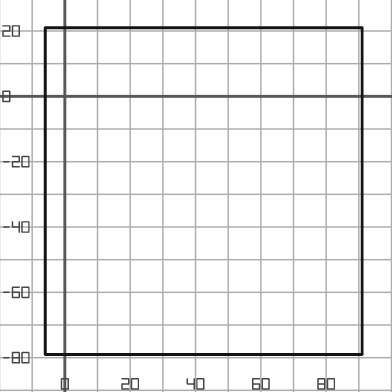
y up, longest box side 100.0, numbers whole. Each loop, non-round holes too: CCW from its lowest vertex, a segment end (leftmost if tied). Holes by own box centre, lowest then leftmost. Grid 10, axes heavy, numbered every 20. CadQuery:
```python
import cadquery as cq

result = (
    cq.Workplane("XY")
    .moveTo(-6.0, -79.0)
    .lineTo(91.0, -79.0)
    .lineTo(91.0, 21.0)
    .lineTo(-6.0, 21.0)
    .close()
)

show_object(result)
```